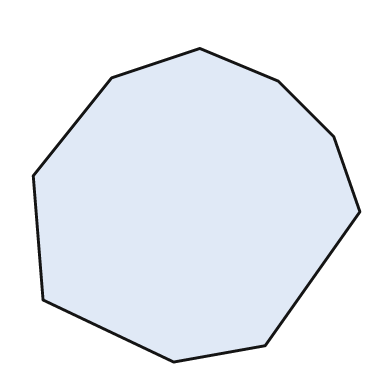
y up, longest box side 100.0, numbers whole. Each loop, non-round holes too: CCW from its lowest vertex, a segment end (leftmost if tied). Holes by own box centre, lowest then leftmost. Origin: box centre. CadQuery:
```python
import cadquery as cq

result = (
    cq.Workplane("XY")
    .moveTo(-7.0, -48.0)
    .lineTo(21.0, -43.0)
    .lineTo(50.0, -2.0)
    .lineTo(42.0, 21.0)
    .lineTo(25.0, 38.0)
    .lineTo(1.0, 48.0)
    .lineTo(-26.0, 39.0)
    .lineTo(-50.0, 9.0)
    .lineTo(-47.0, -29.0)
    .close()
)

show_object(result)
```